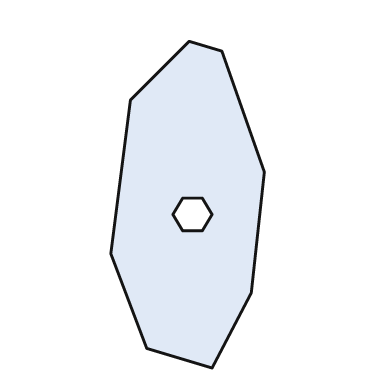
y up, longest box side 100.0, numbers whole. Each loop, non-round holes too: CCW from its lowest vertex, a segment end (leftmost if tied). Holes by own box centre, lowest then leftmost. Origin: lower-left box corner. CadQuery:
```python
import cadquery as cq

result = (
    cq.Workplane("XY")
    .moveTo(31.0, 0.0)
    .lineTo(43.0, 23.0)
    .lineTo(47.0, 60.0)
    .lineTo(34.0, 97.0)
    .lineTo(24.0, 100.0)
    .lineTo(6.0, 82.0)
    .lineTo(0.0, 35.0)
    .lineTo(11.0, 6.0)
    .close()
    .moveTo(22.0, 42.0)
    .lineTo(28.0, 42.0)
    .lineTo(31.0, 47.0)
    .lineTo(28.0, 52.0)
    .lineTo(22.0, 52.0)
    .lineTo(19.0, 47.0)
    .close()
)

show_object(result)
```